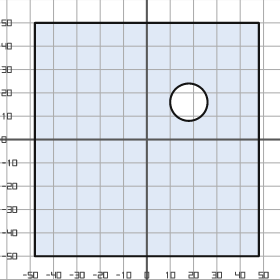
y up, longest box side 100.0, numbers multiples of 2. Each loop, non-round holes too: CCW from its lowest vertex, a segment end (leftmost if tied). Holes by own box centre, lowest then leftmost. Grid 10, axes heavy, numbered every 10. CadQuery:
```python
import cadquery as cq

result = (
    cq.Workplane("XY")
    .moveTo(-48.0, -50.0)
    .lineTo(48.0, -50.0)
    .lineTo(48.0, 50.0)
    .lineTo(-48.0, 50.0)
    .close()
    .moveTo(18.0, 16.0)
    .circle(8.0)
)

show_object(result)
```